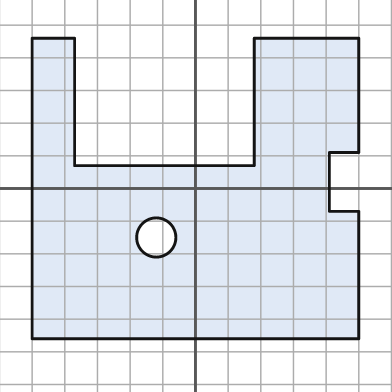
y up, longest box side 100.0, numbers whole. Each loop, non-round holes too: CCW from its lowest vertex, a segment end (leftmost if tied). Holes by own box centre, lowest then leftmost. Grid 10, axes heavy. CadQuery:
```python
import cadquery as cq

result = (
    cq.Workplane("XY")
    .moveTo(-50.0, -46.0)
    .lineTo(50.0, -46.0)
    .lineTo(50.0, -7.0)
    .lineTo(41.0, -7.0)
    .lineTo(41.0, 11.0)
    .lineTo(50.0, 11.0)
    .lineTo(50.0, 46.0)
    .lineTo(18.0, 46.0)
    .lineTo(18.0, 7.0)
    .lineTo(-37.0, 7.0)
    .lineTo(-37.0, 46.0)
    .lineTo(-50.0, 46.0)
    .close()
    .moveTo(-12.0, -15.0)
    .circle(6.0)
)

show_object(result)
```